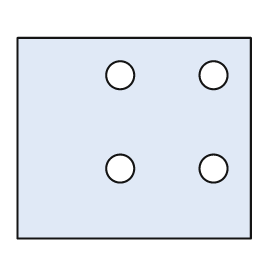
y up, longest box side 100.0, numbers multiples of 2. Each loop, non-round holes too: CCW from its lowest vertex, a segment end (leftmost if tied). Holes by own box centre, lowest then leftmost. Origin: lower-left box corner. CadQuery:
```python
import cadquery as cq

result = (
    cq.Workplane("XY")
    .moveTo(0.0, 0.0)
    .lineTo(100.0, 0.0)
    .lineTo(100.0, 86.0)
    .lineTo(0.0, 86.0)
    .close()
    .moveTo(44.0, 30.0)
    .circle(6.0)
    .moveTo(84.0, 30.0)
    .circle(6.0)
    .moveTo(44.0, 70.0)
    .circle(6.0)
    .moveTo(84.0, 70.0)
    .circle(6.0)
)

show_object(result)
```